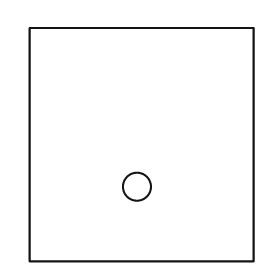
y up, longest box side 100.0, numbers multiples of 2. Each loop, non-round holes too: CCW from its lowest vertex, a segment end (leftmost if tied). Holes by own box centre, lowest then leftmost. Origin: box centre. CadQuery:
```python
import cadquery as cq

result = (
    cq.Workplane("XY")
    .moveTo(-48.0, -50.0)
    .lineTo(48.0, -50.0)
    .lineTo(48.0, 50.0)
    .lineTo(-48.0, 50.0)
    .close()
    .moveTo(-2.0, -18.0)
    .circle(6.0)
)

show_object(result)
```